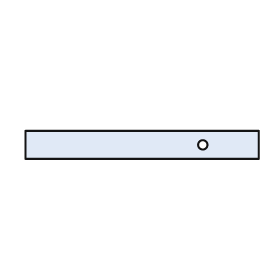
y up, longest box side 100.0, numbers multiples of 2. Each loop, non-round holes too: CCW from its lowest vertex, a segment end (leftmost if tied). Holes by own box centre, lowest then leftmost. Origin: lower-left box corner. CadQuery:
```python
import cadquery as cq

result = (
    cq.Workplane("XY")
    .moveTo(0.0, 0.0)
    .lineTo(100.0, 0.0)
    .lineTo(100.0, 12.0)
    .lineTo(0.0, 12.0)
    .close()
    .moveTo(76.0, 6.0)
    .circle(2.0)
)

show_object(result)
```